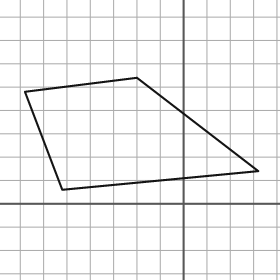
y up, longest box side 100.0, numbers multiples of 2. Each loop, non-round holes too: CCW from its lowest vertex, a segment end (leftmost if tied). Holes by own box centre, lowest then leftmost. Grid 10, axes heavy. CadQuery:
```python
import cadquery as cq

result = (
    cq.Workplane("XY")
    .moveTo(-52.0, 6.0)
    .lineTo(32.0, 14.0)
    .lineTo(-20.0, 54.0)
    .lineTo(-68.0, 48.0)
    .close()
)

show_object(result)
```